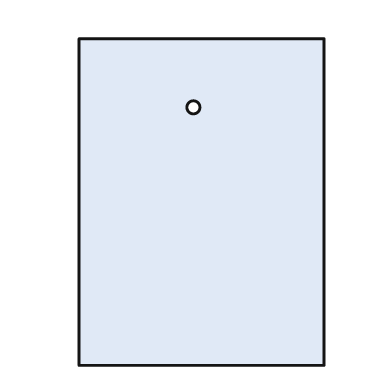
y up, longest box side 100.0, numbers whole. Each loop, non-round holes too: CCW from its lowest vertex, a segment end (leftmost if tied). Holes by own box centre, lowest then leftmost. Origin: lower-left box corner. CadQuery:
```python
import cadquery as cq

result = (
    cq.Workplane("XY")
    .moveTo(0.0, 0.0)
    .lineTo(75.0, 0.0)
    .lineTo(75.0, 100.0)
    .lineTo(0.0, 100.0)
    .close()
    .moveTo(35.0, 79.0)
    .circle(2.0)
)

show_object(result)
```